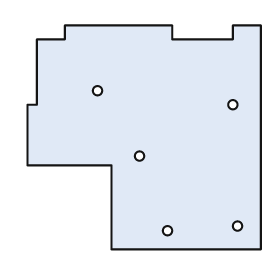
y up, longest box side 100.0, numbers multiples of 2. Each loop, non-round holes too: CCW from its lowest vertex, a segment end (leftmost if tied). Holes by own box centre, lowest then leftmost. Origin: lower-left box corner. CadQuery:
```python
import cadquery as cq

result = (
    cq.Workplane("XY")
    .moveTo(36.0, 0.0)
    .lineTo(100.0, 0.0)
    .lineTo(100.0, 96.0)
    .lineTo(88.0, 96.0)
    .lineTo(88.0, 90.0)
    .lineTo(62.0, 90.0)
    .lineTo(62.0, 96.0)
    .lineTo(16.0, 96.0)
    .lineTo(16.0, 90.0)
    .lineTo(4.0, 90.0)
    .lineTo(4.0, 62.0)
    .lineTo(0.0, 62.0)
    .lineTo(0.0, 36.0)
    .lineTo(36.0, 36.0)
    .close()
    .moveTo(60.0, 8.0)
    .circle(2.0)
    .moveTo(90.0, 10.0)
    .circle(2.0)
    .moveTo(48.0, 40.0)
    .circle(2.0)
    .moveTo(88.0, 62.0)
    .circle(2.0)
    .moveTo(30.0, 68.0)
    .circle(2.0)
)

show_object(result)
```